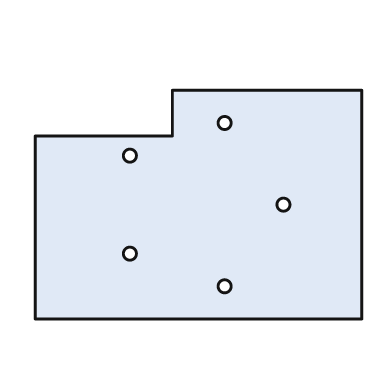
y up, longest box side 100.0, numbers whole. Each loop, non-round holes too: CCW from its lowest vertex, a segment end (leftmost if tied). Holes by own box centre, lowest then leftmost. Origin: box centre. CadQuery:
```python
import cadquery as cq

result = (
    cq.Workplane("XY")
    .moveTo(-50.0, -35.0)
    .lineTo(50.0, -35.0)
    .lineTo(50.0, 35.0)
    .lineTo(-8.0, 35.0)
    .lineTo(-8.0, 21.0)
    .lineTo(-50.0, 21.0)
    .close()
    .moveTo(8.0, -25.0)
    .circle(2.0)
    .moveTo(-21.0, -15.0)
    .circle(2.0)
    .moveTo(26.0, 0.0)
    .circle(2.0)
    .moveTo(-21.0, 15.0)
    .circle(2.0)
    .moveTo(8.0, 25.0)
    .circle(2.0)
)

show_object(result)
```